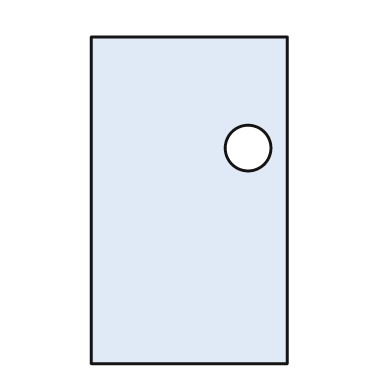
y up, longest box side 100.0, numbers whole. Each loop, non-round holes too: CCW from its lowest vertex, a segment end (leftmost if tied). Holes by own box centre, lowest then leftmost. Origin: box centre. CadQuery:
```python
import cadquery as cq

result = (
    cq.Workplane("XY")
    .moveTo(-30.0, -50.0)
    .lineTo(30.0, -50.0)
    .lineTo(30.0, 50.0)
    .lineTo(-30.0, 50.0)
    .close()
    .moveTo(18.0, 16.0)
    .circle(7.0)
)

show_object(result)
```